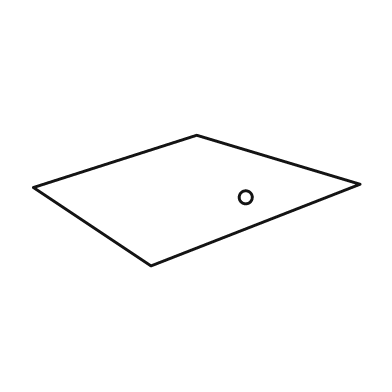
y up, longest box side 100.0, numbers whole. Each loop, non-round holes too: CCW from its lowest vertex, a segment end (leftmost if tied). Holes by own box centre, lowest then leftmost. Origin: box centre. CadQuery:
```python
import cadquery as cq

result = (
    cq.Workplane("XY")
    .moveTo(-14.0, -20.0)
    .lineTo(50.0, 5.0)
    .lineTo(0.0, 20.0)
    .lineTo(-50.0, 4.0)
    .close()
    .moveTo(15.0, 1.0)
    .circle(2.0)
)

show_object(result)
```